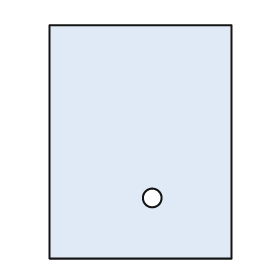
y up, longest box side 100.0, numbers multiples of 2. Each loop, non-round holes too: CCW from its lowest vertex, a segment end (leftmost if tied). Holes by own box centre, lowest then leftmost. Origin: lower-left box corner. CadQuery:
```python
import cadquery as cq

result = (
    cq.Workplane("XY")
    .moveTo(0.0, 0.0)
    .lineTo(78.0, 0.0)
    .lineTo(78.0, 100.0)
    .lineTo(0.0, 100.0)
    .close()
    .moveTo(44.0, 26.0)
    .circle(4.0)
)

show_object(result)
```